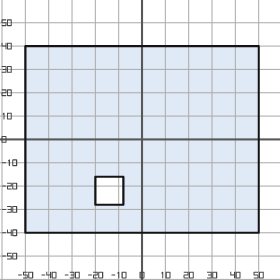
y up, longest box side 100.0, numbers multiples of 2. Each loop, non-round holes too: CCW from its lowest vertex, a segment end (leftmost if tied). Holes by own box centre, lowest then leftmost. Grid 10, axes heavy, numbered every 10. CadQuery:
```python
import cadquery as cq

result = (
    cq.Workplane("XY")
    .moveTo(-50.0, -40.0)
    .lineTo(50.0, -40.0)
    .lineTo(50.0, 40.0)
    .lineTo(-50.0, 40.0)
    .close()
    .moveTo(-20.0, -28.0)
    .lineTo(-8.0, -28.0)
    .lineTo(-8.0, -16.0)
    .lineTo(-20.0, -16.0)
    .close()
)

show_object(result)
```